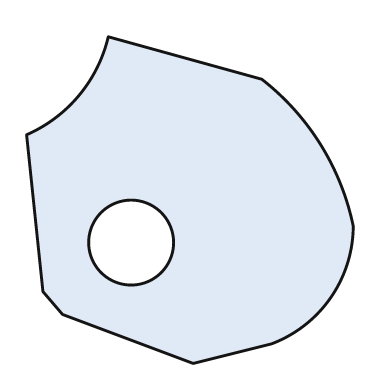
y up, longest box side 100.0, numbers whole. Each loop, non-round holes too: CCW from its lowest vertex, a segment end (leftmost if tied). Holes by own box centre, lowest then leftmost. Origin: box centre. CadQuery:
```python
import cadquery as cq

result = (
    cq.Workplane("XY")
    .moveTo(1.0, -50.0)
    .lineTo(25.0, -44.0)
    .threePointArc((43.0, -30.0), (50.0, -8.0))
    .threePointArc((40.0, 17.0), (22.0, 37.0))
    .lineTo(-25.0, 50.0)
    .threePointArc((-34.0, 32.0), (-50.0, 20.0))
    .lineTo(-45.0, -28.0)
    .lineTo(-39.0, -35.0)
    .close()
    .moveTo(-18.0, -13.0)
    .circle(13.0)
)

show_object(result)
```